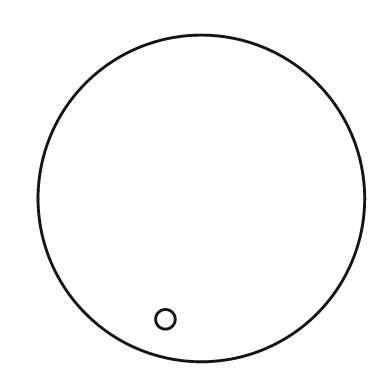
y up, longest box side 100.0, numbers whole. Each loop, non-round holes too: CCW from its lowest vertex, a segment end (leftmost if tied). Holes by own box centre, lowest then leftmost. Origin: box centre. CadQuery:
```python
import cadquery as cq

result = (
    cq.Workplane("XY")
    .moveTo(0.0, 0.0)
    .circle(50.0)
    .moveTo(-11.0, -37.0)
    .circle(3.0)
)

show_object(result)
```